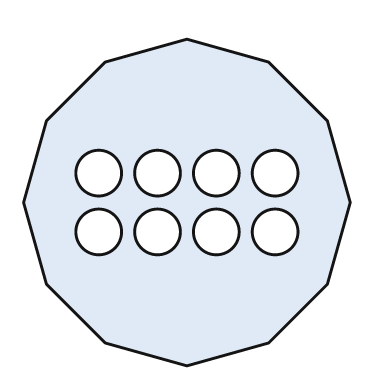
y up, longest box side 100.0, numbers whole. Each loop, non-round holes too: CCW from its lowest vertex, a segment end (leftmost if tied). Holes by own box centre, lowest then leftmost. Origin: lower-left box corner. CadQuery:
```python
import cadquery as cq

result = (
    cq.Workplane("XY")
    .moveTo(50.0, 0.0)
    .lineTo(75.0, 7.0)
    .lineTo(93.0, 25.0)
    .lineTo(100.0, 50.0)
    .lineTo(93.0, 75.0)
    .lineTo(75.0, 93.0)
    .lineTo(50.0, 100.0)
    .lineTo(25.0, 93.0)
    .lineTo(7.0, 75.0)
    .lineTo(0.0, 50.0)
    .lineTo(7.0, 25.0)
    .lineTo(25.0, 7.0)
    .close()
    .moveTo(23.0, 41.0)
    .circle(7.0)
    .moveTo(41.0, 41.0)
    .circle(7.0)
    .moveTo(59.0, 41.0)
    .circle(7.0)
    .moveTo(77.0, 41.0)
    .circle(7.0)
    .moveTo(23.0, 59.0)
    .circle(7.0)
    .moveTo(41.0, 59.0)
    .circle(7.0)
    .moveTo(59.0, 59.0)
    .circle(7.0)
    .moveTo(77.0, 59.0)
    .circle(7.0)
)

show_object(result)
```